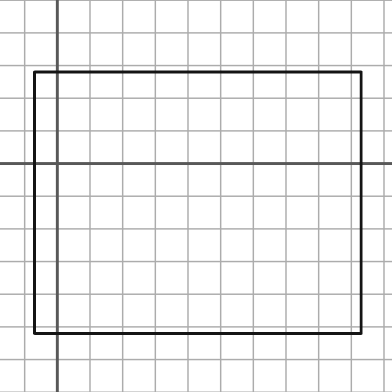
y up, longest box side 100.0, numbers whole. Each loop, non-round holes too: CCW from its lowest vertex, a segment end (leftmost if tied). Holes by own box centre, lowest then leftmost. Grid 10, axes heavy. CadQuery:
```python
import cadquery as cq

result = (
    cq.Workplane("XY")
    .moveTo(-7.0, -52.0)
    .lineTo(93.0, -52.0)
    .lineTo(93.0, 28.0)
    .lineTo(-7.0, 28.0)
    .close()
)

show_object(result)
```